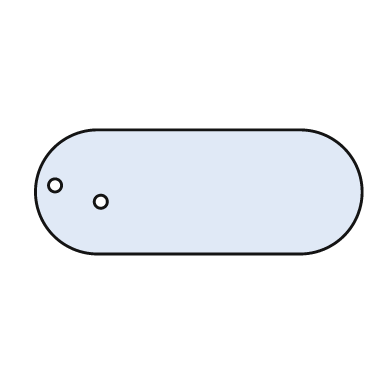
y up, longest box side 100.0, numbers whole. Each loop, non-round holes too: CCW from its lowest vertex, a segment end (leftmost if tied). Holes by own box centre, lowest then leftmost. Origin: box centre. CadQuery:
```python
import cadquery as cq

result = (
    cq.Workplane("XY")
    .moveTo(-31.0, -19.0)
    .lineTo(31.0, -19.0)
    .threePointArc((50.0, 0.0), (31.0, 19.0))
    .lineTo(-31.0, 19.0)
    .threePointArc((-50.0, 0.0), (-31.0, -19.0))
    .close()
    .moveTo(-30.0, -3.0)
    .circle(2.0)
    .moveTo(-44.0, 2.0)
    .circle(2.0)
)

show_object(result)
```